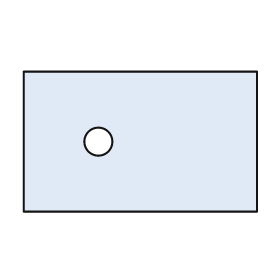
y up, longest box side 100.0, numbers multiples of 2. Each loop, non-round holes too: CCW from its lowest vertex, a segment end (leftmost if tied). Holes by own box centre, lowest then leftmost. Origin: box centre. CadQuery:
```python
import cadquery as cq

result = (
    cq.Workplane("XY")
    .moveTo(-50.0, -30.0)
    .lineTo(50.0, -30.0)
    .lineTo(50.0, 30.0)
    .lineTo(-50.0, 30.0)
    .close()
    .moveTo(-18.0, 0.0)
    .circle(6.0)
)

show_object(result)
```